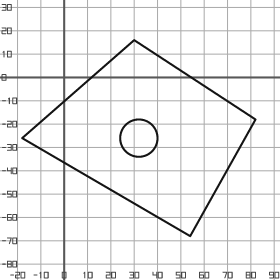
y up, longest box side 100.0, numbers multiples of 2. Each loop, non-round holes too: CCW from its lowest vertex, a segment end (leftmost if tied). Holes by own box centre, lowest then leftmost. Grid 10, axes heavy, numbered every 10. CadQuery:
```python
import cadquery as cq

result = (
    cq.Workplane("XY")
    .moveTo(54.0, -68.0)
    .lineTo(82.0, -18.0)
    .lineTo(30.0, 16.0)
    .lineTo(-18.0, -26.0)
    .close()
    .moveTo(32.0, -26.0)
    .circle(8.0)
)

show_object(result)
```